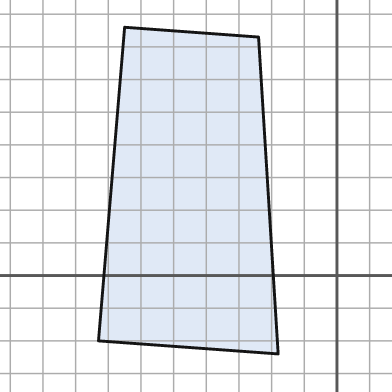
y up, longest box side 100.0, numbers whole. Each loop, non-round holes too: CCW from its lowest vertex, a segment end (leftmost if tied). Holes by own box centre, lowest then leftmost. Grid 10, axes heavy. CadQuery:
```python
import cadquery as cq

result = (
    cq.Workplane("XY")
    .moveTo(-18.0, -24.0)
    .lineTo(-24.0, 73.0)
    .lineTo(-65.0, 76.0)
    .lineTo(-73.0, -20.0)
    .close()
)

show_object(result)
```